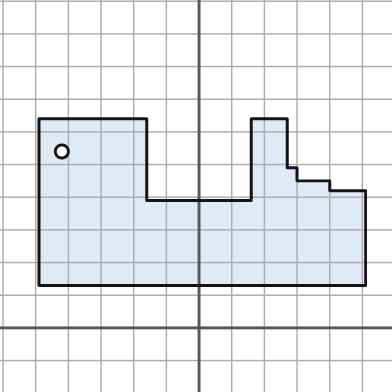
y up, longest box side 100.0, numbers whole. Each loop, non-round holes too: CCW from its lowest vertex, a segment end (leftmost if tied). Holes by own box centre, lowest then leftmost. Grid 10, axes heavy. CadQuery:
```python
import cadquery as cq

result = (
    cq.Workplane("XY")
    .moveTo(-49.0, 13.0)
    .lineTo(51.0, 13.0)
    .lineTo(51.0, 42.0)
    .lineTo(40.0, 42.0)
    .lineTo(40.0, 45.0)
    .lineTo(30.0, 45.0)
    .lineTo(30.0, 49.0)
    .lineTo(27.0, 49.0)
    .lineTo(27.0, 64.0)
    .lineTo(16.0, 64.0)
    .lineTo(16.0, 39.0)
    .lineTo(-16.0, 39.0)
    .lineTo(-16.0, 64.0)
    .lineTo(-49.0, 64.0)
    .close()
    .moveTo(-42.0, 54.0)
    .circle(2.0)
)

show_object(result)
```